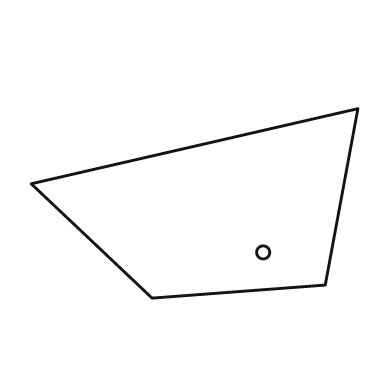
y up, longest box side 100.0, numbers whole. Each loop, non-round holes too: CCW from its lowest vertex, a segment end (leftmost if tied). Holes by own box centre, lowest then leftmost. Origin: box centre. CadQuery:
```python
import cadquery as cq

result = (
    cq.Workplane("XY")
    .moveTo(-13.0, -29.0)
    .lineTo(40.0, -25.0)
    .lineTo(50.0, 29.0)
    .lineTo(-50.0, 6.0)
    .close()
    .moveTo(21.0, -15.0)
    .circle(2.0)
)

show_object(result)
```